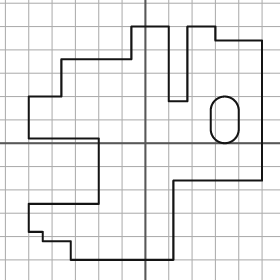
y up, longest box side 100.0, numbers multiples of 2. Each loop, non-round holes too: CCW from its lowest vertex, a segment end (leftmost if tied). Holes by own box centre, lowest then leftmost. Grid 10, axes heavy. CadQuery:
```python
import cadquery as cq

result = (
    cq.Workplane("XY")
    .moveTo(-32.0, -50.0)
    .lineTo(12.0, -50.0)
    .lineTo(12.0, -16.0)
    .lineTo(50.0, -16.0)
    .lineTo(50.0, 44.0)
    .lineTo(30.0, 44.0)
    .lineTo(30.0, 50.0)
    .lineTo(18.0, 50.0)
    .lineTo(18.0, 18.0)
    .lineTo(10.0, 18.0)
    .lineTo(10.0, 50.0)
    .lineTo(-6.0, 50.0)
    .lineTo(-6.0, 36.0)
    .lineTo(-36.0, 36.0)
    .lineTo(-36.0, 20.0)
    .lineTo(-50.0, 20.0)
    .lineTo(-50.0, 2.0)
    .lineTo(-20.0, 2.0)
    .lineTo(-20.0, -26.0)
    .lineTo(-50.0, -26.0)
    .lineTo(-50.0, -38.0)
    .lineTo(-44.0, -38.0)
    .lineTo(-44.0, -42.0)
    .lineTo(-32.0, -42.0)
    .close()
    .moveTo(28.0, 6.0)
    .threePointArc((34.0, 0.0), (40.0, 6.0))
    .lineTo(40.0, 14.0)
    .threePointArc((34.0, 20.0), (28.0, 14.0))
    .close()
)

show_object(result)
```